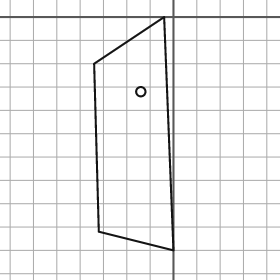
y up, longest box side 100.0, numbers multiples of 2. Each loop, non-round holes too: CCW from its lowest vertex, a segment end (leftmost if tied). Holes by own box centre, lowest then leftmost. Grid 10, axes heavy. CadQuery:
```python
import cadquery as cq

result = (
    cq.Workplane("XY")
    .moveTo(0.0, -100.0)
    .lineTo(-4.0, 0.0)
    .lineTo(-34.0, -20.0)
    .lineTo(-32.0, -92.0)
    .close()
    .moveTo(-14.0, -32.0)
    .circle(2.0)
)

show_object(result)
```